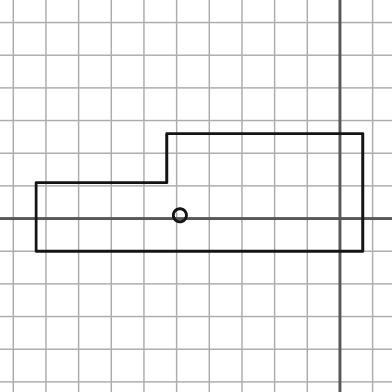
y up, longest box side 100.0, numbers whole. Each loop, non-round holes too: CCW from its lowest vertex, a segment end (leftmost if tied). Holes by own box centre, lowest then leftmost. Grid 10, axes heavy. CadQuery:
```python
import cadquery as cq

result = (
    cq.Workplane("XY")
    .moveTo(-93.0, -10.0)
    .lineTo(7.0, -10.0)
    .lineTo(7.0, 26.0)
    .lineTo(-53.0, 26.0)
    .lineTo(-53.0, 11.0)
    .lineTo(-93.0, 11.0)
    .close()
    .moveTo(-49.0, 1.0)
    .circle(2.0)
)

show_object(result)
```